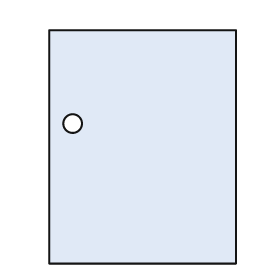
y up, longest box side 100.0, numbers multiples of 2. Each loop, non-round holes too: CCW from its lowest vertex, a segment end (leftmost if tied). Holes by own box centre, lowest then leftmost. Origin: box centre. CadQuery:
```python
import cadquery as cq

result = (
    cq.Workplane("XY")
    .moveTo(-40.0, -50.0)
    .lineTo(40.0, -50.0)
    .lineTo(40.0, 50.0)
    .lineTo(-40.0, 50.0)
    .close()
    .moveTo(-30.0, 10.0)
    .circle(4.0)
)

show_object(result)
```